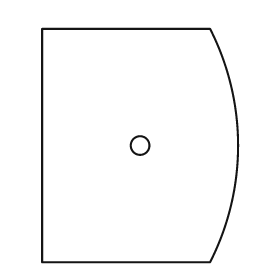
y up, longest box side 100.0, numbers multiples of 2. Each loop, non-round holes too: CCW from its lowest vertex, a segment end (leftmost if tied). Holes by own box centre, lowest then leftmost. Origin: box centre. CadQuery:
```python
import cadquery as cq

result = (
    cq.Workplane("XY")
    .moveTo(-42.0, -50.0)
    .lineTo(30.0, -50.0)
    .threePointArc((42.0, 0.0), (30.0, 50.0))
    .lineTo(-42.0, 50.0)
    .close()
    .moveTo(0.0, 0.0)
    .circle(4.0)
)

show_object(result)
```